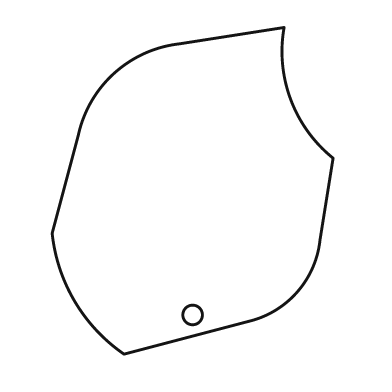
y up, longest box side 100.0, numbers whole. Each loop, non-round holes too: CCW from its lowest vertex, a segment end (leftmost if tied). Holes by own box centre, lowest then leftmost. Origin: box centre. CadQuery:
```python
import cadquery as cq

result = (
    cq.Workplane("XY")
    .moveTo(-21.0, -50.0)
    .lineTo(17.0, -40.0)
    .threePointArc((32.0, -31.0), (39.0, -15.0))
    .lineTo(43.0, 10.0)
    .threePointArc((30.0, 28.0), (28.0, 50.0))
    .lineTo(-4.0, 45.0)
    .threePointArc((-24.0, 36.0), (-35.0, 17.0))
    .lineTo(-43.0, -13.0)
    .threePointArc((-36.0, -34.0), (-21.0, -50.0))
    .close()
    .moveTo(0.0, -38.0)
    .circle(3.0)
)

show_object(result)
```